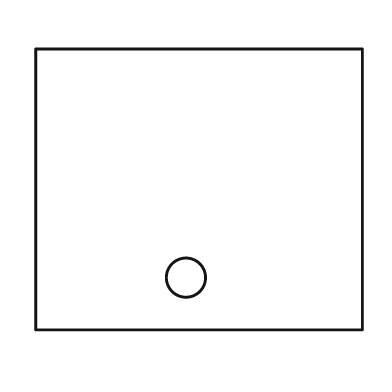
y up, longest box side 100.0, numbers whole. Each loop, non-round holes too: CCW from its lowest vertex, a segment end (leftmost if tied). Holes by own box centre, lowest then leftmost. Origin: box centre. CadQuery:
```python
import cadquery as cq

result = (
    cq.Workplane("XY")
    .moveTo(-50.0, -43.0)
    .lineTo(50.0, -43.0)
    .lineTo(50.0, 43.0)
    .lineTo(-50.0, 43.0)
    .close()
    .moveTo(-4.0, -27.0)
    .circle(6.0)
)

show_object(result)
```